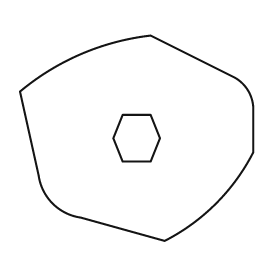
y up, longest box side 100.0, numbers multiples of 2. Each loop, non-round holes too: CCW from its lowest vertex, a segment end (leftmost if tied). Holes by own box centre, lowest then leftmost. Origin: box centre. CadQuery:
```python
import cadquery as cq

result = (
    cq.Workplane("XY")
    .moveTo(12.0, -44.0)
    .threePointArc((34.0, -28.0), (50.0, -6.0))
    .lineTo(50.0, 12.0)
    .threePointArc((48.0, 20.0), (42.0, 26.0))
    .lineTo(6.0, 44.0)
    .threePointArc((-24.0, 36.0), (-50.0, 20.0))
    .lineTo(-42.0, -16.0)
    .threePointArc((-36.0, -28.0), (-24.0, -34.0))
    .close()
    .moveTo(-6.0, -10.0)
    .lineTo(6.0, -10.0)
    .lineTo(10.0, 0.0)
    .lineTo(6.0, 10.0)
    .lineTo(-6.0, 10.0)
    .lineTo(-10.0, 0.0)
    .close()
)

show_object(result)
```